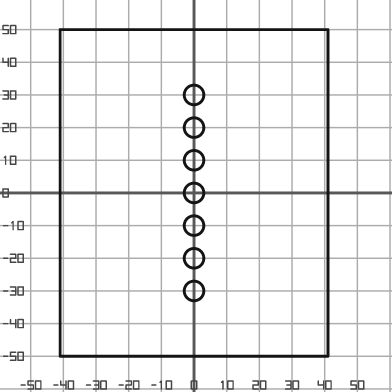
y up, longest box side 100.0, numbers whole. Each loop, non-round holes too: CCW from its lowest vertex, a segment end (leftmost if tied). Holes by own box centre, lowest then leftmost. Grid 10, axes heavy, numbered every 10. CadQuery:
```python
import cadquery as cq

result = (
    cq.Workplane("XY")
    .moveTo(-41.0, -50.0)
    .lineTo(41.0, -50.0)
    .lineTo(41.0, 50.0)
    .lineTo(-41.0, 50.0)
    .close()
    .moveTo(0.0, -30.0)
    .circle(3.0)
    .moveTo(0.0, -20.0)
    .circle(3.0)
    .moveTo(0.0, -10.0)
    .circle(3.0)
    .moveTo(0.0, 0.0)
    .circle(3.0)
    .moveTo(0.0, 10.0)
    .circle(3.0)
    .moveTo(0.0, 20.0)
    .circle(3.0)
    .moveTo(0.0, 30.0)
    .circle(3.0)
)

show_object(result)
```